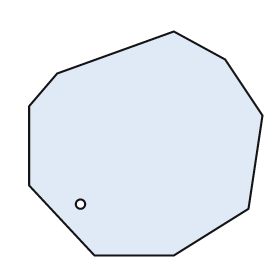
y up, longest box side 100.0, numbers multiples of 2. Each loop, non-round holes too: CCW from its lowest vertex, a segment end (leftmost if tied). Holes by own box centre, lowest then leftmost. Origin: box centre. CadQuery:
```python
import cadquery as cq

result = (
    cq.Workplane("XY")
    .moveTo(-22.0, -48.0)
    .lineTo(12.0, -48.0)
    .lineTo(44.0, -28.0)
    .lineTo(50.0, 12.0)
    .lineTo(34.0, 36.0)
    .lineTo(12.0, 48.0)
    .lineTo(-38.0, 30.0)
    .lineTo(-50.0, 16.0)
    .lineTo(-50.0, -18.0)
    .close()
    .moveTo(-28.0, -26.0)
    .circle(2.0)
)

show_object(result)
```